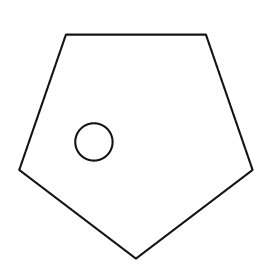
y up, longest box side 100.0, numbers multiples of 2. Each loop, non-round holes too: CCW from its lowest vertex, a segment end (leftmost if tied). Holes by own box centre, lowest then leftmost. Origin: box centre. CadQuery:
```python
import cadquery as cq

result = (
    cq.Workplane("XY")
    .moveTo(0.0, -48.0)
    .lineTo(50.0, -10.0)
    .lineTo(30.0, 48.0)
    .lineTo(-30.0, 48.0)
    .lineTo(-50.0, -10.0)
    .close()
    .moveTo(-18.0, 2.0)
    .circle(8.0)
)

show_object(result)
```